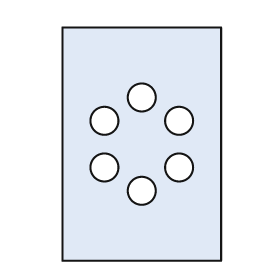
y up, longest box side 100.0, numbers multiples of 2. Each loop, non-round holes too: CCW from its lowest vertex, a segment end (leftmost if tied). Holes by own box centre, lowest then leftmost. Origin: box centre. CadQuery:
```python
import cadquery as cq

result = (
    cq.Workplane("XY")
    .moveTo(-34.0, -50.0)
    .lineTo(34.0, -50.0)
    .lineTo(34.0, 50.0)
    .lineTo(-34.0, 50.0)
    .close()
    .moveTo(0.0, -20.0)
    .circle(6.0)
    .moveTo(-16.0, -10.0)
    .circle(6.0)
    .moveTo(16.0, -10.0)
    .circle(6.0)
    .moveTo(-16.0, 10.0)
    .circle(6.0)
    .moveTo(16.0, 10.0)
    .circle(6.0)
    .moveTo(0.0, 20.0)
    .circle(6.0)
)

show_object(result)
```